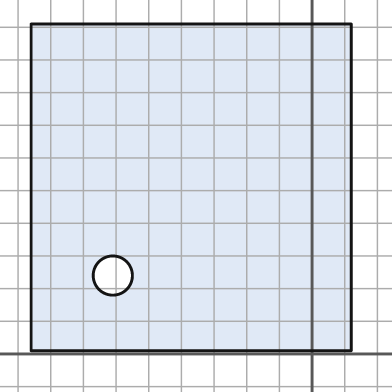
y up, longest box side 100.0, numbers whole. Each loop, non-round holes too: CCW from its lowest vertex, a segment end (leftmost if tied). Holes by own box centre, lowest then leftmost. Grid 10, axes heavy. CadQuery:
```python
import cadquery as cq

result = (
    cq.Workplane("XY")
    .moveTo(-86.0, 1.0)
    .lineTo(12.0, 1.0)
    .lineTo(12.0, 101.0)
    .lineTo(-86.0, 101.0)
    .close()
    .moveTo(-61.0, 24.0)
    .circle(6.0)
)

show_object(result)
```